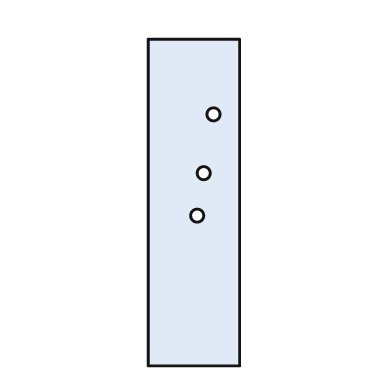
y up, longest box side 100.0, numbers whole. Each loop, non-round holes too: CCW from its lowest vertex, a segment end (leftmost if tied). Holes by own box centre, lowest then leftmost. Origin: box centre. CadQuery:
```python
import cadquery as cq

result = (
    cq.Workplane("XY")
    .moveTo(-14.0, -50.0)
    .lineTo(14.0, -50.0)
    .lineTo(14.0, 50.0)
    .lineTo(-14.0, 50.0)
    .close()
    .moveTo(1.0, -4.0)
    .circle(2.0)
    .moveTo(3.0, 9.0)
    .circle(2.0)
    .moveTo(6.0, 27.0)
    .circle(2.0)
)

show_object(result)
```